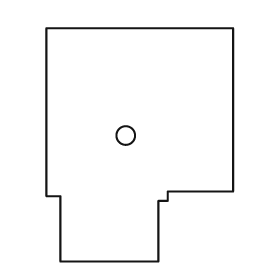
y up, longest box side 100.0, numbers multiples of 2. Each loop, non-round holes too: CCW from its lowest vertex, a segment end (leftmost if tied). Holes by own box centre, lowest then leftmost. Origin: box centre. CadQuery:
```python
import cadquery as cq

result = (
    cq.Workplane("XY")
    .moveTo(-34.0, -50.0)
    .lineTo(8.0, -50.0)
    .lineTo(8.0, -24.0)
    .lineTo(12.0, -24.0)
    .lineTo(12.0, -20.0)
    .lineTo(40.0, -20.0)
    .lineTo(40.0, 50.0)
    .lineTo(-40.0, 50.0)
    .lineTo(-40.0, -22.0)
    .lineTo(-34.0, -22.0)
    .close()
    .moveTo(-6.0, 4.0)
    .circle(4.0)
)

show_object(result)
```